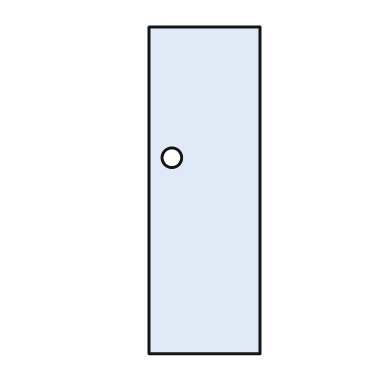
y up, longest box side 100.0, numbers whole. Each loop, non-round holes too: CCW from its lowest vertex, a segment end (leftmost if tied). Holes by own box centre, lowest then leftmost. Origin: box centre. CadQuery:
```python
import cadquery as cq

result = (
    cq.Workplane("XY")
    .moveTo(-17.0, -50.0)
    .lineTo(17.0, -50.0)
    .lineTo(17.0, 50.0)
    .lineTo(-17.0, 50.0)
    .close()
    .moveTo(-10.0, 10.0)
    .circle(3.0)
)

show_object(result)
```